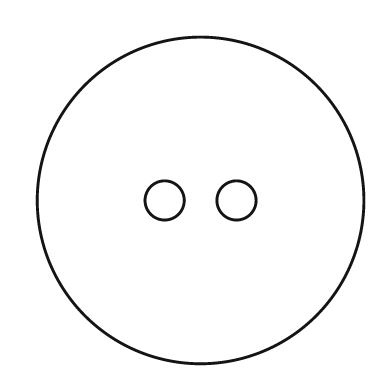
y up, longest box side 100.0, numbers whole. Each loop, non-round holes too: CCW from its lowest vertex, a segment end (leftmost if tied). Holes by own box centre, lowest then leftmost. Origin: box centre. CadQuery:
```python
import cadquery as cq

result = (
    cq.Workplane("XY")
    .moveTo(0.0, 0.0)
    .circle(50.0)
    .moveTo(-11.0, 0.0)
    .circle(6.0)
    .moveTo(11.0, 0.0)
    .circle(6.0)
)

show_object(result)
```